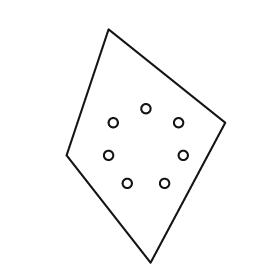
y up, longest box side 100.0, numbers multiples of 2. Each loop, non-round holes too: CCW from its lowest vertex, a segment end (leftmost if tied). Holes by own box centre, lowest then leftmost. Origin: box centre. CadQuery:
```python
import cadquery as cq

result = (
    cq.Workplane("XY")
    .moveTo(2.0, -50.0)
    .lineTo(34.0, 10.0)
    .lineTo(-16.0, 50.0)
    .lineTo(-34.0, -4.0)
    .close()
    .moveTo(-8.0, -16.0)
    .circle(2.0)
    .moveTo(8.0, -16.0)
    .circle(2.0)
    .moveTo(-16.0, -4.0)
    .circle(2.0)
    .moveTo(16.0, -4.0)
    .circle(2.0)
    .moveTo(-14.0, 10.0)
    .circle(2.0)
    .moveTo(14.0, 10.0)
    .circle(2.0)
    .moveTo(0.0, 16.0)
    .circle(2.0)
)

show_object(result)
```